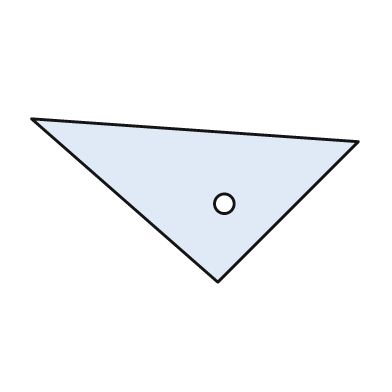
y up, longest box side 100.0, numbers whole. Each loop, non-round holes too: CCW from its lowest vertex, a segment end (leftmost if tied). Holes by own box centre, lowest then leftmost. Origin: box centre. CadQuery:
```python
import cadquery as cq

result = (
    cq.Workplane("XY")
    .moveTo(7.0, -25.0)
    .lineTo(50.0, 18.0)
    .lineTo(-50.0, 25.0)
    .close()
    .moveTo(9.0, -1.0)
    .circle(3.0)
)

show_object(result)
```